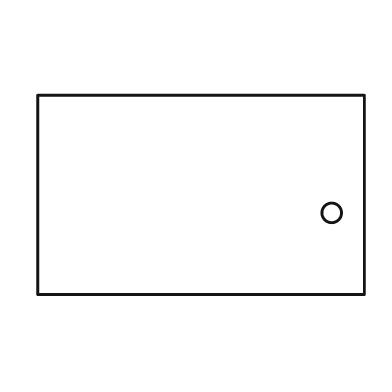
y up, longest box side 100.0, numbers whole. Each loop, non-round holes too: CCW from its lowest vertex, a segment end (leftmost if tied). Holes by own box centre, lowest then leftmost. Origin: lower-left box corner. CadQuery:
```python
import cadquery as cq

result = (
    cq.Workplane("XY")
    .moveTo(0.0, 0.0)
    .lineTo(100.0, 0.0)
    .lineTo(100.0, 61.0)
    .lineTo(0.0, 61.0)
    .close()
    .moveTo(90.0, 25.0)
    .circle(3.0)
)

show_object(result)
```